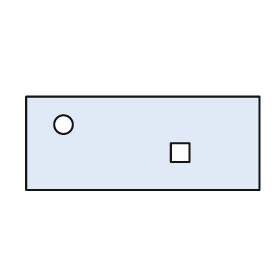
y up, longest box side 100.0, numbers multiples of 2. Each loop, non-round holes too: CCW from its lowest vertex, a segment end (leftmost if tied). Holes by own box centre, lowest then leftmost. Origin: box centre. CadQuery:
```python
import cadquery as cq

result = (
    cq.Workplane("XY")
    .moveTo(-50.0, -20.0)
    .lineTo(50.0, -20.0)
    .lineTo(50.0, 20.0)
    .lineTo(-50.0, 20.0)
    .close()
    .moveTo(12.0, -8.0)
    .lineTo(20.0, -8.0)
    .lineTo(20.0, 0.0)
    .lineTo(12.0, 0.0)
    .close()
    .moveTo(-34.0, 8.0)
    .circle(4.0)
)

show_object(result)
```